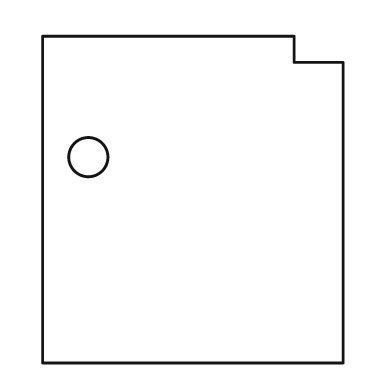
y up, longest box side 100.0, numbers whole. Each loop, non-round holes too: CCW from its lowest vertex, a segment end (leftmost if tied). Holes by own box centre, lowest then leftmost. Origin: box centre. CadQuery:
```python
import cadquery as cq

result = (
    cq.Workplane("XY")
    .moveTo(-46.0, -50.0)
    .lineTo(46.0, -50.0)
    .lineTo(46.0, 42.0)
    .lineTo(31.0, 42.0)
    .lineTo(31.0, 50.0)
    .lineTo(-46.0, 50.0)
    .close()
    .moveTo(-32.0, 13.0)
    .circle(6.0)
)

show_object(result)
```